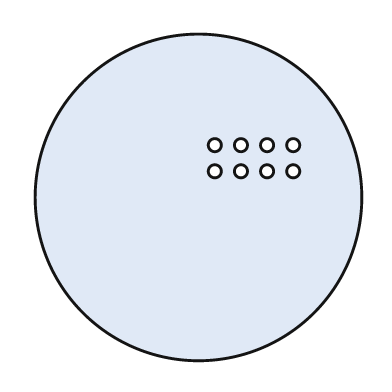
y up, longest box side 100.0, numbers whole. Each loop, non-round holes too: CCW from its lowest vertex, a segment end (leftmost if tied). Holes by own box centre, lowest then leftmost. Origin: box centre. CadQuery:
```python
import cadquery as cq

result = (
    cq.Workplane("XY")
    .moveTo(0.0, 0.0)
    .circle(50.0)
    .moveTo(5.0, 8.0)
    .circle(2.0)
    .moveTo(13.0, 8.0)
    .circle(2.0)
    .moveTo(21.0, 8.0)
    .circle(2.0)
    .moveTo(29.0, 8.0)
    .circle(2.0)
    .moveTo(5.0, 16.0)
    .circle(2.0)
    .moveTo(13.0, 16.0)
    .circle(2.0)
    .moveTo(21.0, 16.0)
    .circle(2.0)
    .moveTo(29.0, 16.0)
    .circle(2.0)
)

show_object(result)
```